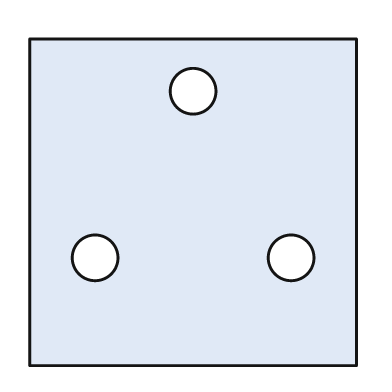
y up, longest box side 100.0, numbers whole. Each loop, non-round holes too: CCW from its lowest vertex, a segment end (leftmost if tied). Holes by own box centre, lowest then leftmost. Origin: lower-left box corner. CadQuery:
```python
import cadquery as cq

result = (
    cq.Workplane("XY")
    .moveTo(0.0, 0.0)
    .lineTo(100.0, 0.0)
    .lineTo(100.0, 100.0)
    .lineTo(0.0, 100.0)
    .close()
    .moveTo(20.0, 33.0)
    .circle(7.0)
    .moveTo(80.0, 33.0)
    .circle(7.0)
    .moveTo(50.0, 84.0)
    .circle(7.0)
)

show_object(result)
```